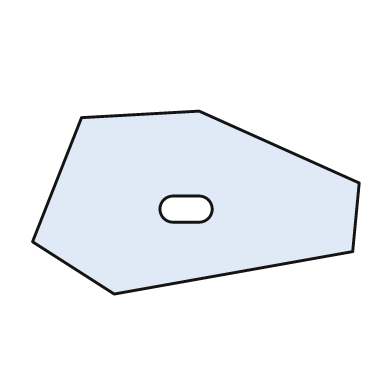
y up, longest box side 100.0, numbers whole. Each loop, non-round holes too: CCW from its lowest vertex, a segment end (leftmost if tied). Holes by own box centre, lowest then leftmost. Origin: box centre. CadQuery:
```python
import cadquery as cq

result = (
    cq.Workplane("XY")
    .moveTo(-25.0, -28.0)
    .lineTo(48.0, -15.0)
    .lineTo(50.0, 6.0)
    .lineTo(1.0, 28.0)
    .lineTo(-35.0, 26.0)
    .lineTo(-50.0, -12.0)
    .close()
    .moveTo(-7.0, -6.0)
    .lineTo(1.0, -6.0)
    .threePointArc((5.0, -2.0), (1.0, 2.0))
    .lineTo(-7.0, 2.0)
    .threePointArc((-11.0, -2.0), (-7.0, -6.0))
    .close()
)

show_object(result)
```